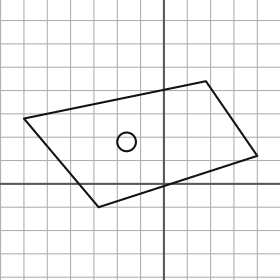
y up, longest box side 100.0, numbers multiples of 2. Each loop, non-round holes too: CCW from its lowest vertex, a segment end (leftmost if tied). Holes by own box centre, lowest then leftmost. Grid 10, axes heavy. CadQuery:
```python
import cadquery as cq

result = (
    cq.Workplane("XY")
    .moveTo(-28.0, -10.0)
    .lineTo(40.0, 12.0)
    .lineTo(18.0, 44.0)
    .lineTo(-60.0, 28.0)
    .close()
    .moveTo(-16.0, 18.0)
    .circle(4.0)
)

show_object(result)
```